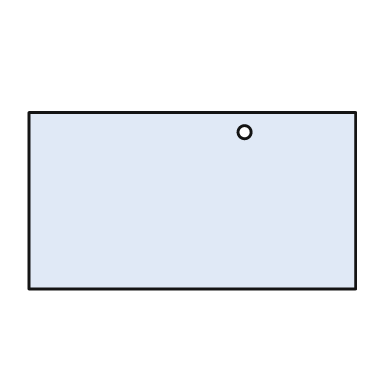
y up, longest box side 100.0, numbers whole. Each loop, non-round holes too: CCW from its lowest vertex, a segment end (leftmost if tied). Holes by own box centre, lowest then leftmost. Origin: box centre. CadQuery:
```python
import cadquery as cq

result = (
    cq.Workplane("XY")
    .moveTo(-50.0, -27.0)
    .lineTo(50.0, -27.0)
    .lineTo(50.0, 27.0)
    .lineTo(-50.0, 27.0)
    .close()
    .moveTo(16.0, 21.0)
    .circle(2.0)
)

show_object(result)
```